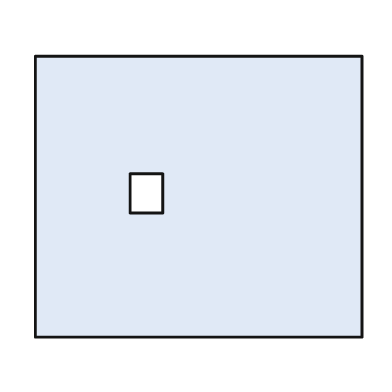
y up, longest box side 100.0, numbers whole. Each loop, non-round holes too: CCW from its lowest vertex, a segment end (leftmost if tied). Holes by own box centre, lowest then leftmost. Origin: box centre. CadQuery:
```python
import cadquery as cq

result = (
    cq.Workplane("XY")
    .moveTo(-50.0, -43.0)
    .lineTo(50.0, -43.0)
    .lineTo(50.0, 43.0)
    .lineTo(-50.0, 43.0)
    .close()
    .moveTo(-21.0, -5.0)
    .lineTo(-11.0, -5.0)
    .lineTo(-11.0, 7.0)
    .lineTo(-21.0, 7.0)
    .close()
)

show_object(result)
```